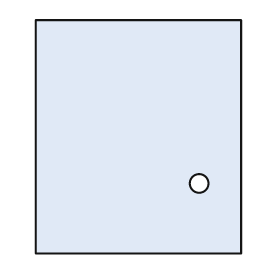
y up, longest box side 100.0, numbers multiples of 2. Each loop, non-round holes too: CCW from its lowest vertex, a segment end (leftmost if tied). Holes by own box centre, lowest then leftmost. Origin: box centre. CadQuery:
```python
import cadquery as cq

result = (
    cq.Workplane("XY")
    .moveTo(-44.0, -50.0)
    .lineTo(44.0, -50.0)
    .lineTo(44.0, 50.0)
    .lineTo(-44.0, 50.0)
    .close()
    .moveTo(26.0, -20.0)
    .circle(4.0)
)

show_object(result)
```